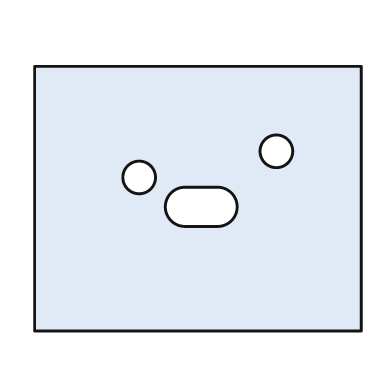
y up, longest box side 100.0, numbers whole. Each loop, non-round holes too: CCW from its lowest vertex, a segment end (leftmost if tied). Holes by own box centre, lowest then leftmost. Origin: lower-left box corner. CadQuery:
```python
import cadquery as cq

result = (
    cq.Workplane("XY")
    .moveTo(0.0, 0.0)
    .lineTo(100.0, 0.0)
    .lineTo(100.0, 81.0)
    .lineTo(0.0, 81.0)
    .close()
    .moveTo(46.0, 32.0)
    .lineTo(56.0, 32.0)
    .threePointArc((62.0, 38.0), (56.0, 44.0))
    .lineTo(46.0, 44.0)
    .threePointArc((40.0, 38.0), (46.0, 32.0))
    .close()
    .moveTo(32.0, 47.0)
    .circle(5.0)
    .moveTo(74.0, 55.0)
    .circle(5.0)
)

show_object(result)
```